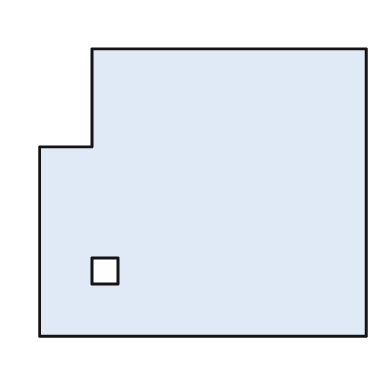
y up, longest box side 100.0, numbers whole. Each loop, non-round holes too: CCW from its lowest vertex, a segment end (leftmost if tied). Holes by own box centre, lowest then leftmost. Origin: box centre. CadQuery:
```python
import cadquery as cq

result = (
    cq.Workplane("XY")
    .moveTo(-50.0, -44.0)
    .lineTo(50.0, -44.0)
    .lineTo(50.0, 44.0)
    .lineTo(-34.0, 44.0)
    .lineTo(-34.0, 14.0)
    .lineTo(-50.0, 14.0)
    .close()
    .moveTo(-34.0, -28.0)
    .lineTo(-26.0, -28.0)
    .lineTo(-26.0, -20.0)
    .lineTo(-34.0, -20.0)
    .close()
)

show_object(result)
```